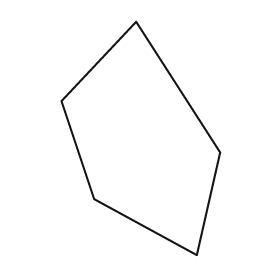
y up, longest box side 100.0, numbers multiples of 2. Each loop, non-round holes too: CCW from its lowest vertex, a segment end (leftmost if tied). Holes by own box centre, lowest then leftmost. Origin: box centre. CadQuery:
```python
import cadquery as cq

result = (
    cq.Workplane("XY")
    .moveTo(24.0, -50.0)
    .lineTo(34.0, -6.0)
    .lineTo(-2.0, 50.0)
    .lineTo(-34.0, 16.0)
    .lineTo(-20.0, -26.0)
    .close()
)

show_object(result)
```